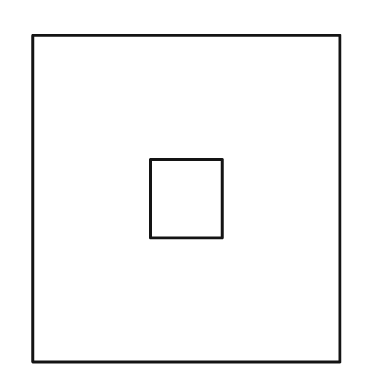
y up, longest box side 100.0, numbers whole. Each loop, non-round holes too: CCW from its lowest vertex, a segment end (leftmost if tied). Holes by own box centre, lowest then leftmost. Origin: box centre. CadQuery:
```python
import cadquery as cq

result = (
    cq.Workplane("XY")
    .moveTo(-47.0, -50.0)
    .lineTo(47.0, -50.0)
    .lineTo(47.0, 50.0)
    .lineTo(-47.0, 50.0)
    .close()
    .moveTo(-11.0, -12.0)
    .lineTo(11.0, -12.0)
    .lineTo(11.0, 12.0)
    .lineTo(-11.0, 12.0)
    .close()
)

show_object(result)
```